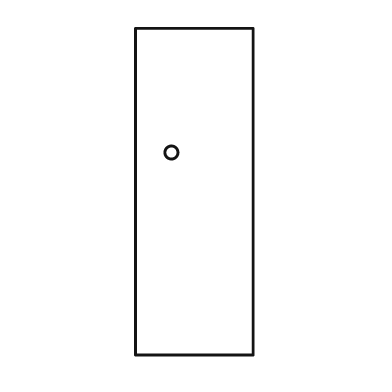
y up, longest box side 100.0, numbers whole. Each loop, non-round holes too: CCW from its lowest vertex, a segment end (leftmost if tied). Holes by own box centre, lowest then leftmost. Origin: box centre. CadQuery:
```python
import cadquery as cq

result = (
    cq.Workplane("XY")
    .moveTo(-18.0, -50.0)
    .lineTo(18.0, -50.0)
    .lineTo(18.0, 50.0)
    .lineTo(-18.0, 50.0)
    .close()
    .moveTo(-7.0, 12.0)
    .circle(2.0)
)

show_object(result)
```